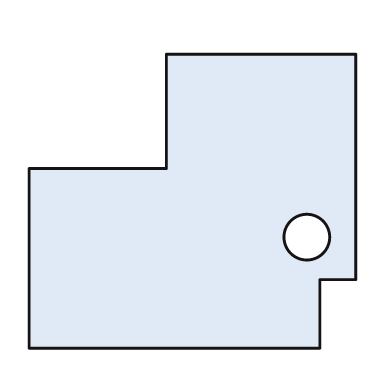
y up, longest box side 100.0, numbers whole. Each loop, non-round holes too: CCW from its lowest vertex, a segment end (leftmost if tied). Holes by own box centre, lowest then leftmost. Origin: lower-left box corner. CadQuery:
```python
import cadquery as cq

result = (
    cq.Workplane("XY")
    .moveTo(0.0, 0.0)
    .lineTo(89.0, 0.0)
    .lineTo(89.0, 21.0)
    .lineTo(100.0, 21.0)
    .lineTo(100.0, 90.0)
    .lineTo(42.0, 90.0)
    .lineTo(42.0, 55.0)
    .lineTo(0.0, 55.0)
    .close()
    .moveTo(85.0, 34.0)
    .circle(7.0)
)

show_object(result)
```